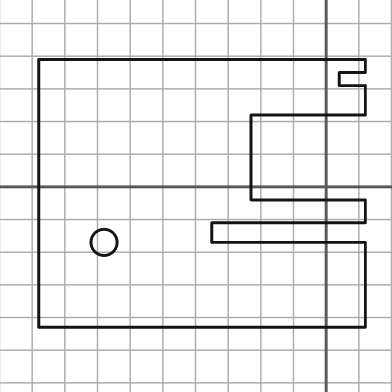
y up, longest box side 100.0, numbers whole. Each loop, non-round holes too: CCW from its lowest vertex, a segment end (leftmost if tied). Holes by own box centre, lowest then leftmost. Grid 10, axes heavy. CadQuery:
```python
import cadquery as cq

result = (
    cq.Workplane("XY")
    .moveTo(-88.0, -43.0)
    .lineTo(12.0, -43.0)
    .lineTo(12.0, -17.0)
    .lineTo(-35.0, -17.0)
    .lineTo(-35.0, -11.0)
    .lineTo(12.0, -11.0)
    .lineTo(12.0, -4.0)
    .lineTo(-23.0, -4.0)
    .lineTo(-23.0, 22.0)
    .lineTo(12.0, 22.0)
    .lineTo(12.0, 31.0)
    .lineTo(4.0, 31.0)
    .lineTo(4.0, 35.0)
    .lineTo(12.0, 35.0)
    .lineTo(12.0, 39.0)
    .lineTo(-88.0, 39.0)
    .close()
    .moveTo(-68.0, -17.0)
    .circle(4.0)
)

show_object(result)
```